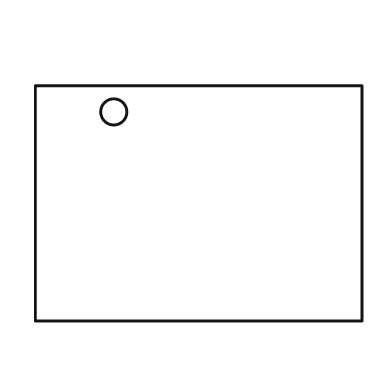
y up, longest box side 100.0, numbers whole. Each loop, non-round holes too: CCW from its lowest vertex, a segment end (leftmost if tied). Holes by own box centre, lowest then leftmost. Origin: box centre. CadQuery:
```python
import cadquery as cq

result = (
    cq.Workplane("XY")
    .moveTo(-50.0, -36.0)
    .lineTo(50.0, -36.0)
    .lineTo(50.0, 36.0)
    .lineTo(-50.0, 36.0)
    .close()
    .moveTo(-26.0, 28.0)
    .circle(4.0)
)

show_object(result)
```